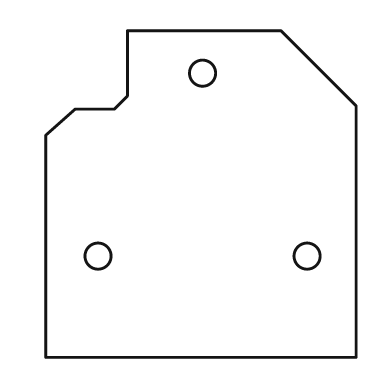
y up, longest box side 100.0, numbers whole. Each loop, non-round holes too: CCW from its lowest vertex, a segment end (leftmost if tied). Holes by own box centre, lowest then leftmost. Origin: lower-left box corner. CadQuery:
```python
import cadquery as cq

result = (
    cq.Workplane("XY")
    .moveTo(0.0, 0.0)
    .lineTo(95.0, 0.0)
    .lineTo(95.0, 77.0)
    .lineTo(72.0, 100.0)
    .lineTo(25.0, 100.0)
    .lineTo(25.0, 80.0)
    .lineTo(21.0, 76.0)
    .lineTo(9.0, 76.0)
    .lineTo(0.0, 68.0)
    .close()
    .moveTo(16.0, 31.0)
    .circle(4.0)
    .moveTo(80.0, 31.0)
    .circle(4.0)
    .moveTo(48.0, 87.0)
    .circle(4.0)
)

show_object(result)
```